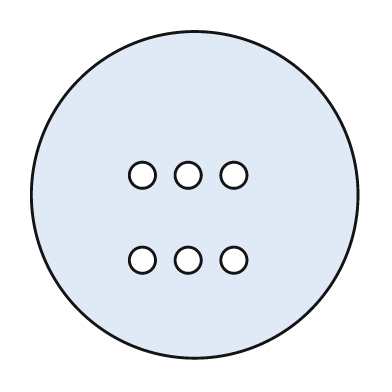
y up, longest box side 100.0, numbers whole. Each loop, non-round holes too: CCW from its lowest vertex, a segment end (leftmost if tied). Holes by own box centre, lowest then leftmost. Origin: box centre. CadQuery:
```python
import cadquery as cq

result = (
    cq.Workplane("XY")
    .moveTo(0.0, 0.0)
    .circle(50.0)
    .moveTo(-16.0, -20.0)
    .circle(4.0)
    .moveTo(-2.0, -20.0)
    .circle(4.0)
    .moveTo(12.0, -20.0)
    .circle(4.0)
    .moveTo(-16.0, 6.0)
    .circle(4.0)
    .moveTo(-2.0, 6.0)
    .circle(4.0)
    .moveTo(12.0, 6.0)
    .circle(4.0)
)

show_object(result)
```